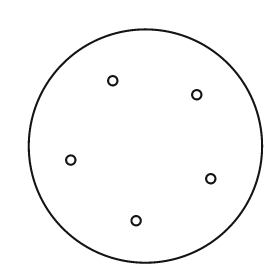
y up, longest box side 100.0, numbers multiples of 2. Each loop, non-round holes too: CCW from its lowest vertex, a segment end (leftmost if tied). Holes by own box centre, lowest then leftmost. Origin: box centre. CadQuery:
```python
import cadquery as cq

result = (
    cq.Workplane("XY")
    .moveTo(0.0, 0.0)
    .circle(50.0)
    .moveTo(-4.0, -32.0)
    .circle(2.0)
    .moveTo(28.0, -14.0)
    .circle(2.0)
    .moveTo(-32.0, -6.0)
    .circle(2.0)
    .moveTo(22.0, 22.0)
    .circle(2.0)
    .moveTo(-14.0, 28.0)
    .circle(2.0)
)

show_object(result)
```